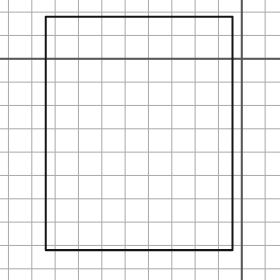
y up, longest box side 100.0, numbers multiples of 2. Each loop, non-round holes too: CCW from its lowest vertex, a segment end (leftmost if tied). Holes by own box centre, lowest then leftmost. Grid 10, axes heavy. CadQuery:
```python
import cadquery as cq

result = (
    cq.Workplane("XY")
    .moveTo(-84.0, -82.0)
    .lineTo(-4.0, -82.0)
    .lineTo(-4.0, 18.0)
    .lineTo(-84.0, 18.0)
    .close()
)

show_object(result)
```